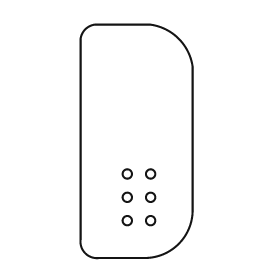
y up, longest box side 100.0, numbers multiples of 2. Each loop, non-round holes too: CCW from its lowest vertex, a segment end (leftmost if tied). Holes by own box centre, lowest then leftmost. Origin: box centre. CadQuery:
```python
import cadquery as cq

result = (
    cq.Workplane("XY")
    .moveTo(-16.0, -50.0)
    .lineTo(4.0, -50.0)
    .threePointArc((18.0, -44.0), (24.0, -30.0))
    .lineTo(24.0, 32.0)
    .threePointArc((18.0, 44.0), (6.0, 50.0))
    .lineTo(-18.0, 50.0)
    .threePointArc((-22.0, 48.0), (-24.0, 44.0))
    .lineTo(-24.0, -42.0)
    .threePointArc((-22.0, -48.0), (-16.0, -50.0))
    .close()
    .moveTo(-4.0, -34.0)
    .circle(2.0)
    .moveTo(6.0, -34.0)
    .circle(2.0)
    .moveTo(-4.0, -24.0)
    .circle(2.0)
    .moveTo(6.0, -24.0)
    .circle(2.0)
    .moveTo(-4.0, -14.0)
    .circle(2.0)
    .moveTo(6.0, -14.0)
    .circle(2.0)
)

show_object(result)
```